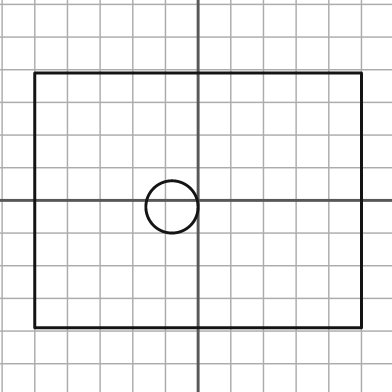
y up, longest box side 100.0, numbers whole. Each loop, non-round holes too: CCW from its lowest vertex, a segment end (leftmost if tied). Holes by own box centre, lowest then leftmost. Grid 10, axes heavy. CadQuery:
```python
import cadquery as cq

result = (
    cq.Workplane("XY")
    .moveTo(-50.0, -39.0)
    .lineTo(50.0, -39.0)
    .lineTo(50.0, 39.0)
    .lineTo(-50.0, 39.0)
    .close()
    .moveTo(-8.0, -2.0)
    .circle(8.0)
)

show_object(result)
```